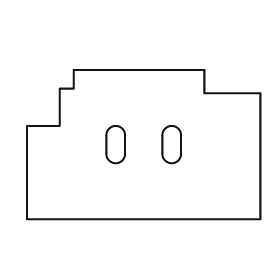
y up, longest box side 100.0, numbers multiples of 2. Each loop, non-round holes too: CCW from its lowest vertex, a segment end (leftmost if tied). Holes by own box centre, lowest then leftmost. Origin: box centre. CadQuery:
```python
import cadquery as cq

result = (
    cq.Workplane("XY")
    .moveTo(-50.0, -32.0)
    .lineTo(50.0, -32.0)
    .lineTo(50.0, 22.0)
    .lineTo(26.0, 22.0)
    .lineTo(26.0, 32.0)
    .lineTo(-30.0, 32.0)
    .lineTo(-30.0, 24.0)
    .lineTo(-36.0, 24.0)
    .lineTo(-36.0, 8.0)
    .lineTo(-50.0, 8.0)
    .close()
    .moveTo(-16.0, -4.0)
    .threePointArc((-12.0, -8.0), (-8.0, -4.0))
    .lineTo(-8.0, 4.0)
    .threePointArc((-12.0, 8.0), (-16.0, 4.0))
    .close()
    .moveTo(8.0, -4.0)
    .threePointArc((12.0, -8.0), (16.0, -4.0))
    .lineTo(16.0, 4.0)
    .threePointArc((12.0, 8.0), (8.0, 4.0))
    .close()
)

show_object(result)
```